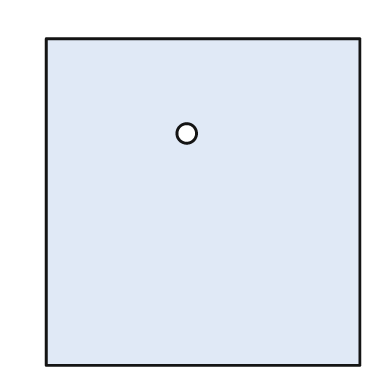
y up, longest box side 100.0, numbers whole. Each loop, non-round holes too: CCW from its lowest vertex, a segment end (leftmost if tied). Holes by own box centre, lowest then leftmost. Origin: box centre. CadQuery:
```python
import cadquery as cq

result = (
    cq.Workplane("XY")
    .moveTo(-48.0, -50.0)
    .lineTo(48.0, -50.0)
    .lineTo(48.0, 50.0)
    .lineTo(-48.0, 50.0)
    .close()
    .moveTo(-5.0, 21.0)
    .circle(3.0)
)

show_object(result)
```